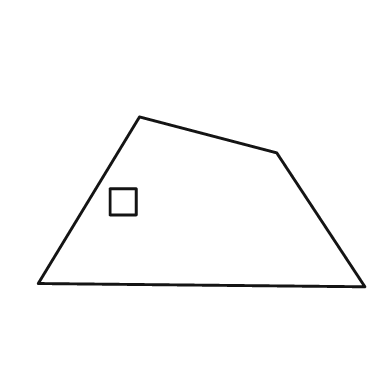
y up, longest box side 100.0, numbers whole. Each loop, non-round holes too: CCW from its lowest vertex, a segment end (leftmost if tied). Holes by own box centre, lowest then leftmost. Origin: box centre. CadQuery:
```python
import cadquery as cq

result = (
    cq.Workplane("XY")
    .moveTo(50.0, -26.0)
    .lineTo(23.0, 15.0)
    .lineTo(-19.0, 26.0)
    .lineTo(-50.0, -25.0)
    .close()
    .moveTo(-28.0, -4.0)
    .lineTo(-20.0, -4.0)
    .lineTo(-20.0, 4.0)
    .lineTo(-28.0, 4.0)
    .close()
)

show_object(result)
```